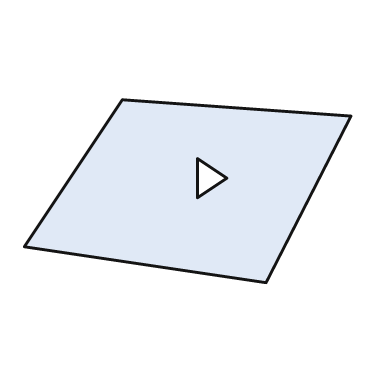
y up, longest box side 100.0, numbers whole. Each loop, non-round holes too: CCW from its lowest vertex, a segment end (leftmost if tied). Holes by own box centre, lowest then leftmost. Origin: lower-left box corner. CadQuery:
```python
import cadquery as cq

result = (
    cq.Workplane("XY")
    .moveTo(74.0, 0.0)
    .lineTo(100.0, 51.0)
    .lineTo(30.0, 56.0)
    .lineTo(0.0, 11.0)
    .close()
    .moveTo(53.0, 26.0)
    .lineTo(62.0, 32.0)
    .lineTo(53.0, 38.0)
    .close()
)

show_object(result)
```